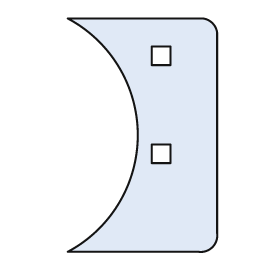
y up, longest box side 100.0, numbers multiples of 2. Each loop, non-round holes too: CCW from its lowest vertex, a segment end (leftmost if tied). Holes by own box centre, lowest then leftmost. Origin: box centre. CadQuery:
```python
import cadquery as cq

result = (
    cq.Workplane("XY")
    .moveTo(-32.0, -50.0)
    .lineTo(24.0, -50.0)
    .threePointArc((30.0, -48.0), (32.0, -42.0))
    .lineTo(32.0, 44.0)
    .threePointArc((30.0, 48.0), (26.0, 50.0))
    .lineTo(-32.0, 50.0)
    .threePointArc((-2.0, 0.0), (-32.0, -50.0))
    .close()
    .moveTo(4.0, -12.0)
    .lineTo(12.0, -12.0)
    .lineTo(12.0, -4.0)
    .lineTo(4.0, -4.0)
    .close()
    .moveTo(4.0, 30.0)
    .lineTo(12.0, 30.0)
    .lineTo(12.0, 38.0)
    .lineTo(4.0, 38.0)
    .close()
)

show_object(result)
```